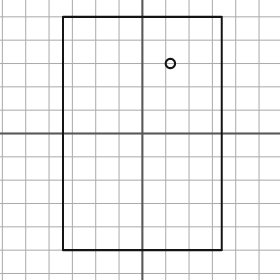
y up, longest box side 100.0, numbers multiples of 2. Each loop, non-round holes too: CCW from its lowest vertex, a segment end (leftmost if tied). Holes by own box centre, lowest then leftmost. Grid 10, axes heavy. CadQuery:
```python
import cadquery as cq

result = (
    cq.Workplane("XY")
    .moveTo(-34.0, -50.0)
    .lineTo(34.0, -50.0)
    .lineTo(34.0, 50.0)
    .lineTo(-34.0, 50.0)
    .close()
    .moveTo(12.0, 30.0)
    .circle(2.0)
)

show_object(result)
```